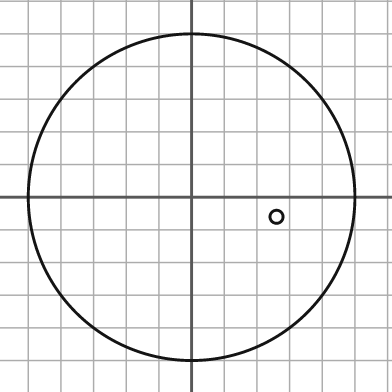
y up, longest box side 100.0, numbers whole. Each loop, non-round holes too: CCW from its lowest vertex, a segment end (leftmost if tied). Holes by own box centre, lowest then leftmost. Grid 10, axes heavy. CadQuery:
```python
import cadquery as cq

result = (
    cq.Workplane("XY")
    .moveTo(0.0, 0.0)
    .circle(50.0)
    .moveTo(26.0, -6.0)
    .circle(2.0)
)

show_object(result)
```